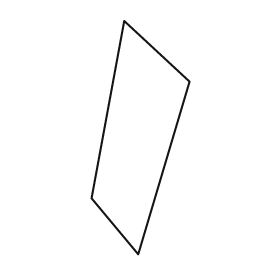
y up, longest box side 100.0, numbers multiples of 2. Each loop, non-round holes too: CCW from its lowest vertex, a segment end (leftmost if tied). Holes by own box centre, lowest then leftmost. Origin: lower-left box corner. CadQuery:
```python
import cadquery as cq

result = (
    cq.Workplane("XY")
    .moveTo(20.0, 0.0)
    .lineTo(42.0, 74.0)
    .lineTo(14.0, 100.0)
    .lineTo(0.0, 24.0)
    .close()
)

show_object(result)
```